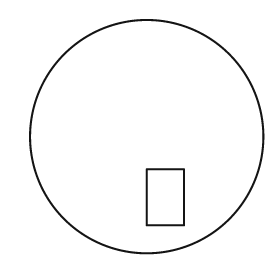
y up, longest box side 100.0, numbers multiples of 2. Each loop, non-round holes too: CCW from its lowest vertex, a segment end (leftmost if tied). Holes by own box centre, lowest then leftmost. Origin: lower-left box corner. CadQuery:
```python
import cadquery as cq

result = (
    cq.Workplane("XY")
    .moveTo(50.0, 50.0)
    .circle(50.0)
    .moveTo(50.0, 12.0)
    .lineTo(66.0, 12.0)
    .lineTo(66.0, 36.0)
    .lineTo(50.0, 36.0)
    .close()
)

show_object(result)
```